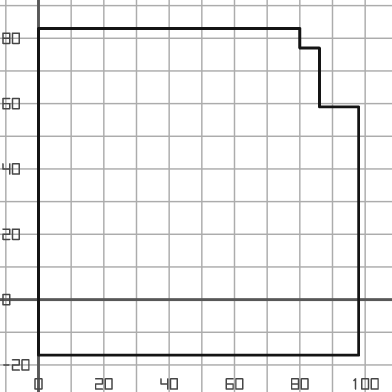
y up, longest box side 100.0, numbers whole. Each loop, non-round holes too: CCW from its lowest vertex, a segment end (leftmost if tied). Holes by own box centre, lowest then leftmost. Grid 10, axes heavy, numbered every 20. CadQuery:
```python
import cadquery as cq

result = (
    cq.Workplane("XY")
    .moveTo(0.0, -17.0)
    .lineTo(98.0, -17.0)
    .lineTo(98.0, 59.0)
    .lineTo(86.0, 59.0)
    .lineTo(86.0, 77.0)
    .lineTo(80.0, 77.0)
    .lineTo(80.0, 83.0)
    .lineTo(0.0, 83.0)
    .close()
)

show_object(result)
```